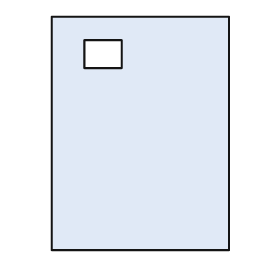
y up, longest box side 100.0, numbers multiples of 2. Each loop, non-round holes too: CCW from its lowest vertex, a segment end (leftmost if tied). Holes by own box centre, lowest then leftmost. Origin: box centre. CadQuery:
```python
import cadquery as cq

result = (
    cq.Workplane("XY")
    .moveTo(-38.0, -50.0)
    .lineTo(38.0, -50.0)
    .lineTo(38.0, 50.0)
    .lineTo(-38.0, 50.0)
    .close()
    .moveTo(-24.0, 28.0)
    .lineTo(-8.0, 28.0)
    .lineTo(-8.0, 40.0)
    .lineTo(-24.0, 40.0)
    .close()
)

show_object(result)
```